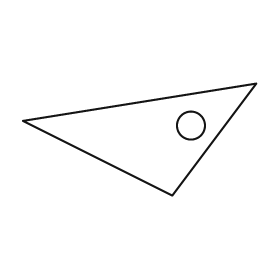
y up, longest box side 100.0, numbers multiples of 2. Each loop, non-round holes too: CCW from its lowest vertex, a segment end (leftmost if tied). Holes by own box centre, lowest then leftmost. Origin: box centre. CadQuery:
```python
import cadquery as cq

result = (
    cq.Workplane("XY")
    .moveTo(14.0, -24.0)
    .lineTo(50.0, 24.0)
    .lineTo(-50.0, 8.0)
    .close()
    .moveTo(22.0, 6.0)
    .circle(6.0)
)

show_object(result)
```